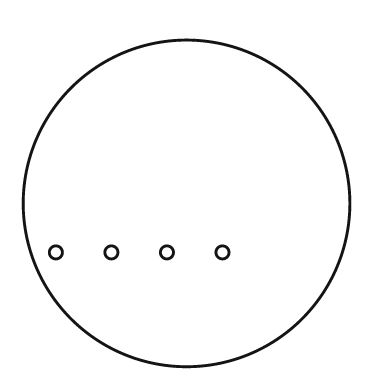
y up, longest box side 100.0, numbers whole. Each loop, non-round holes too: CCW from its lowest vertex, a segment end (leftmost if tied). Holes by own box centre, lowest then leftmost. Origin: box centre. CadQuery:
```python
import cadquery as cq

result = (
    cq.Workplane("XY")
    .moveTo(0.0, 0.0)
    .circle(50.0)
    .moveTo(-40.0, -15.0)
    .circle(2.0)
    .moveTo(-23.0, -15.0)
    .circle(2.0)
    .moveTo(-6.0, -15.0)
    .circle(2.0)
    .moveTo(11.0, -15.0)
    .circle(2.0)
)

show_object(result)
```